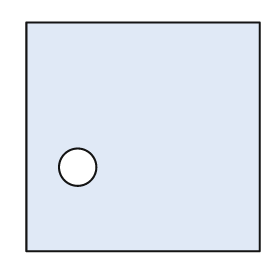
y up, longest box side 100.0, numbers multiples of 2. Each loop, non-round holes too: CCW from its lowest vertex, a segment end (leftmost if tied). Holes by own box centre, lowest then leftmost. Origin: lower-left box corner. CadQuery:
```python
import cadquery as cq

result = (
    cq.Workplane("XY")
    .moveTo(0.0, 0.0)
    .lineTo(100.0, 0.0)
    .lineTo(100.0, 98.0)
    .lineTo(0.0, 98.0)
    .close()
    .moveTo(22.0, 36.0)
    .circle(8.0)
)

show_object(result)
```